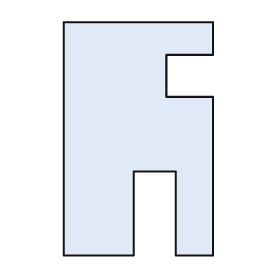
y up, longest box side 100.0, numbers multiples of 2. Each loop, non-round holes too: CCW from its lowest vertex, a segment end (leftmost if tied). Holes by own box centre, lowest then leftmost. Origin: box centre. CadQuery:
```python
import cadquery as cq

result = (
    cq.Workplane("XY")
    .moveTo(-32.0, -50.0)
    .lineTo(-2.0, -50.0)
    .lineTo(-2.0, -14.0)
    .lineTo(16.0, -14.0)
    .lineTo(16.0, -50.0)
    .lineTo(32.0, -50.0)
    .lineTo(32.0, 18.0)
    .lineTo(12.0, 18.0)
    .lineTo(12.0, 36.0)
    .lineTo(32.0, 36.0)
    .lineTo(32.0, 50.0)
    .lineTo(-32.0, 50.0)
    .close()
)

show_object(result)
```